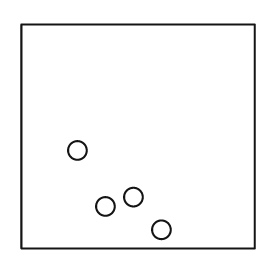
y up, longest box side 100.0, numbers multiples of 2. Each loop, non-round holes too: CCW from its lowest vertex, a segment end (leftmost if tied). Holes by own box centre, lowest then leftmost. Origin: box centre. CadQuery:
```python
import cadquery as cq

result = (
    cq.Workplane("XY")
    .moveTo(-50.0, -48.0)
    .lineTo(50.0, -48.0)
    .lineTo(50.0, 48.0)
    .lineTo(-50.0, 48.0)
    .close()
    .moveTo(10.0, -40.0)
    .circle(4.0)
    .moveTo(-14.0, -30.0)
    .circle(4.0)
    .moveTo(-2.0, -26.0)
    .circle(4.0)
    .moveTo(-26.0, -6.0)
    .circle(4.0)
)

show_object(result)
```